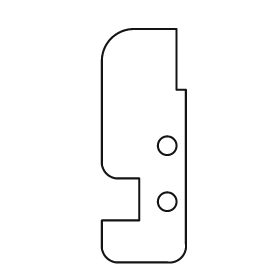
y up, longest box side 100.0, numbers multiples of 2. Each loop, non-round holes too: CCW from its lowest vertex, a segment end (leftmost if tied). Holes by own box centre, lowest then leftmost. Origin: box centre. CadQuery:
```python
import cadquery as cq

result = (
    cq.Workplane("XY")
    .moveTo(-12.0, -50.0)
    .lineTo(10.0, -50.0)
    .threePointArc((16.0, -48.0), (18.0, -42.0))
    .lineTo(18.0, 24.0)
    .lineTo(14.0, 24.0)
    .lineTo(14.0, 50.0)
    .lineTo(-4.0, 50.0)
    .threePointArc((-14.0, 46.0), (-18.0, 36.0))
    .lineTo(-18.0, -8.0)
    .threePointArc((-16.0, -12.0), (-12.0, -14.0))
    .lineTo(-2.0, -14.0)
    .lineTo(-2.0, -32.0)
    .lineTo(-18.0, -32.0)
    .lineTo(-18.0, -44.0)
    .threePointArc((-16.0, -48.0), (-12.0, -50.0))
    .close()
    .moveTo(10.0, -24.0)
    .circle(4.0)
    .moveTo(10.0, 0.0)
    .circle(4.0)
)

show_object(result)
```